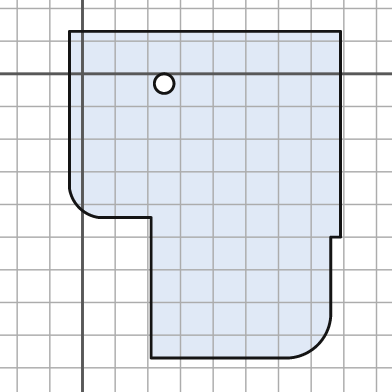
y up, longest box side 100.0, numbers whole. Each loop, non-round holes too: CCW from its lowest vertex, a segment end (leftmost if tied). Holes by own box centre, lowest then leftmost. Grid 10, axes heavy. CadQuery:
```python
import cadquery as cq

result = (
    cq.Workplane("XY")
    .moveTo(21.0, -87.0)
    .lineTo(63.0, -87.0)
    .threePointArc((72.0, -83.0), (76.0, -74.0))
    .lineTo(76.0, -50.0)
    .lineTo(79.0, -50.0)
    .lineTo(79.0, 13.0)
    .lineTo(-4.0, 13.0)
    .lineTo(-4.0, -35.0)
    .threePointArc((-1.0, -41.0), (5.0, -44.0))
    .lineTo(21.0, -44.0)
    .close()
    .moveTo(25.0, -3.0)
    .circle(3.0)
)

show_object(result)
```